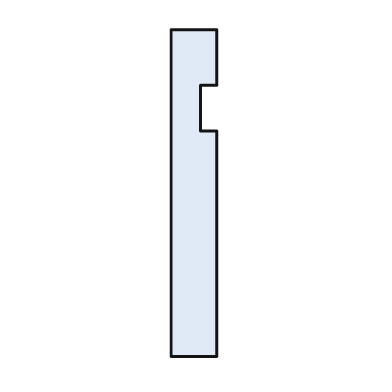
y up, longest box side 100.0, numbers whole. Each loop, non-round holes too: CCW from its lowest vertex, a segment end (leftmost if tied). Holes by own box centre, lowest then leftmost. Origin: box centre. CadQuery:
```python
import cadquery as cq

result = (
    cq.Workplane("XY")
    .moveTo(-7.0, -50.0)
    .lineTo(7.0, -50.0)
    .lineTo(7.0, 19.0)
    .lineTo(2.0, 19.0)
    .lineTo(2.0, 33.0)
    .lineTo(7.0, 33.0)
    .lineTo(7.0, 50.0)
    .lineTo(-7.0, 50.0)
    .close()
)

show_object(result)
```